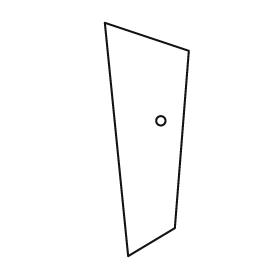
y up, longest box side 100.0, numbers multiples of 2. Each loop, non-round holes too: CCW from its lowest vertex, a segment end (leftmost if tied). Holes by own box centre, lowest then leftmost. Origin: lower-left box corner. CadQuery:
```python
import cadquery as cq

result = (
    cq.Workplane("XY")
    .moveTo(10.0, 0.0)
    .lineTo(30.0, 12.0)
    .lineTo(36.0, 88.0)
    .lineTo(0.0, 100.0)
    .close()
    .moveTo(24.0, 58.0)
    .circle(2.0)
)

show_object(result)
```